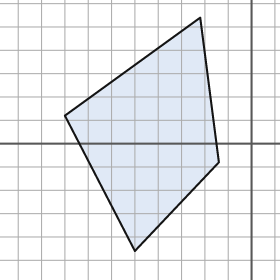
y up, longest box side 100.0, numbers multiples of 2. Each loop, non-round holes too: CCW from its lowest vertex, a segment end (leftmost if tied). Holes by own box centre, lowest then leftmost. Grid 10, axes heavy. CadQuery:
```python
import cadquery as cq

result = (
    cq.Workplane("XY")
    .moveTo(-50.0, -46.0)
    .lineTo(-14.0, -8.0)
    .lineTo(-22.0, 54.0)
    .lineTo(-80.0, 12.0)
    .close()
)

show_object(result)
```